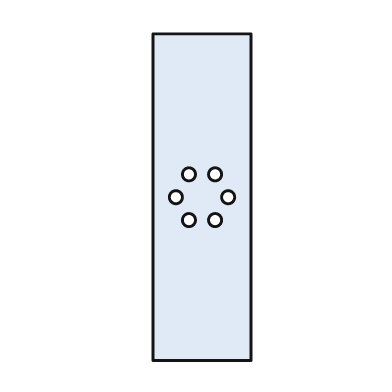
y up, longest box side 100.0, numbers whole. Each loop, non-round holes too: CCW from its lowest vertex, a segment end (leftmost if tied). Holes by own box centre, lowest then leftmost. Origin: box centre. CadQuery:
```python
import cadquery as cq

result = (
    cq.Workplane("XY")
    .moveTo(-15.0, -50.0)
    .lineTo(15.0, -50.0)
    .lineTo(15.0, 50.0)
    .lineTo(-15.0, 50.0)
    .close()
    .moveTo(-4.0, -7.0)
    .circle(2.0)
    .moveTo(4.0, -7.0)
    .circle(2.0)
    .moveTo(-8.0, 0.0)
    .circle(2.0)
    .moveTo(8.0, 0.0)
    .circle(2.0)
    .moveTo(-4.0, 7.0)
    .circle(2.0)
    .moveTo(4.0, 7.0)
    .circle(2.0)
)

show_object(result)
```